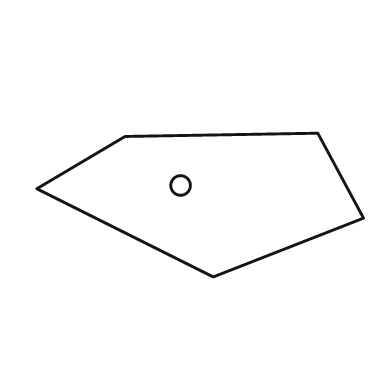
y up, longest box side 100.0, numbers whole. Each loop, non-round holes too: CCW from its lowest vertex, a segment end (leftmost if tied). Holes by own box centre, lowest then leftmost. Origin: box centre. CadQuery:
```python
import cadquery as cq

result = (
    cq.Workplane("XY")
    .moveTo(4.0, -22.0)
    .lineTo(50.0, -4.0)
    .lineTo(36.0, 22.0)
    .lineTo(-23.0, 21.0)
    .lineTo(-50.0, 5.0)
    .close()
    .moveTo(-6.0, 6.0)
    .circle(3.0)
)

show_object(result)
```